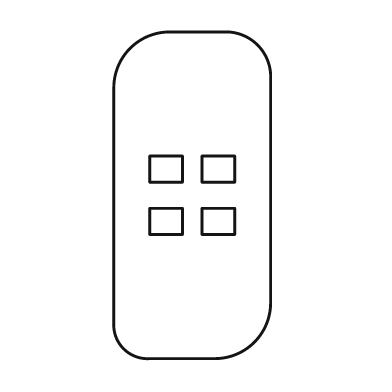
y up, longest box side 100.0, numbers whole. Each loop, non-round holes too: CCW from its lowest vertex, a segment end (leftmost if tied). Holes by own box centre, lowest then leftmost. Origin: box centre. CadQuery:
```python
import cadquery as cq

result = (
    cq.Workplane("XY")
    .moveTo(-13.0, -50.0)
    .lineTo(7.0, -50.0)
    .threePointArc((19.0, -45.0), (24.0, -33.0))
    .lineTo(24.0, 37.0)
    .threePointArc((20.0, 46.0), (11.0, 50.0))
    .lineTo(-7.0, 50.0)
    .threePointArc((-19.0, 45.0), (-24.0, 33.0))
    .lineTo(-24.0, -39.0)
    .threePointArc((-21.0, -47.0), (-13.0, -50.0))
    .close()
    .moveTo(-13.0, -12.0)
    .lineTo(-3.0, -12.0)
    .lineTo(-3.0, -4.0)
    .lineTo(-13.0, -4.0)
    .close()
    .moveTo(3.0, -12.0)
    .lineTo(13.0, -12.0)
    .lineTo(13.0, -4.0)
    .lineTo(3.0, -4.0)
    .close()
    .moveTo(-13.0, 4.0)
    .lineTo(-3.0, 4.0)
    .lineTo(-3.0, 12.0)
    .lineTo(-13.0, 12.0)
    .close()
    .moveTo(3.0, 4.0)
    .lineTo(13.0, 4.0)
    .lineTo(13.0, 12.0)
    .lineTo(3.0, 12.0)
    .close()
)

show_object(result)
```